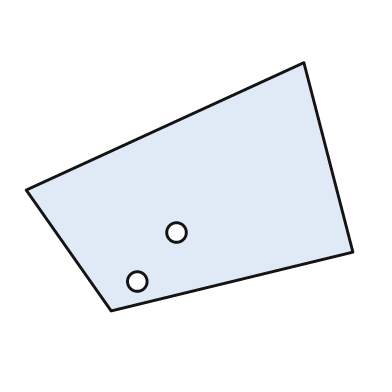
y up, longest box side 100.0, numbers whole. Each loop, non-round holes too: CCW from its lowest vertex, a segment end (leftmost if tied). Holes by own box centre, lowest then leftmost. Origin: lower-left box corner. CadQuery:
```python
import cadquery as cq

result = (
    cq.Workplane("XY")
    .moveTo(26.0, 0.0)
    .lineTo(100.0, 18.0)
    .lineTo(85.0, 76.0)
    .lineTo(0.0, 37.0)
    .close()
    .moveTo(34.0, 9.0)
    .circle(3.0)
    .moveTo(46.0, 24.0)
    .circle(3.0)
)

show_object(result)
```